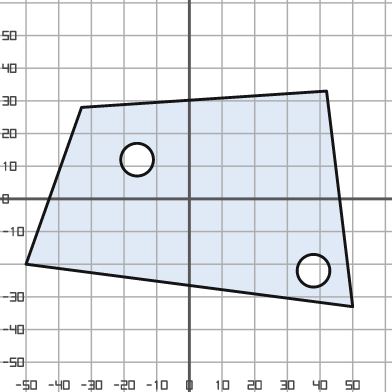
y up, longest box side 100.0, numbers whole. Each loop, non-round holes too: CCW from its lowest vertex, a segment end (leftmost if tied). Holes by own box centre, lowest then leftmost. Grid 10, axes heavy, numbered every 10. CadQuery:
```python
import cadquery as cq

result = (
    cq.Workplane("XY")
    .moveTo(50.0, -33.0)
    .lineTo(42.0, 33.0)
    .lineTo(-33.0, 28.0)
    .lineTo(-50.0, -20.0)
    .close()
    .moveTo(38.0, -22.0)
    .circle(5.0)
    .moveTo(-16.0, 12.0)
    .circle(5.0)
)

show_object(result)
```